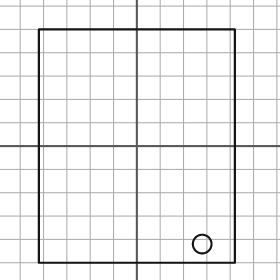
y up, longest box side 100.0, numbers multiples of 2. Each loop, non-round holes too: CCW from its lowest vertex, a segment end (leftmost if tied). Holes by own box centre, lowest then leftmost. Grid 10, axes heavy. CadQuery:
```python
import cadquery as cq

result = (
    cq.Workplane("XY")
    .moveTo(-42.0, -50.0)
    .lineTo(42.0, -50.0)
    .lineTo(42.0, 50.0)
    .lineTo(-42.0, 50.0)
    .close()
    .moveTo(28.0, -42.0)
    .circle(4.0)
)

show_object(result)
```